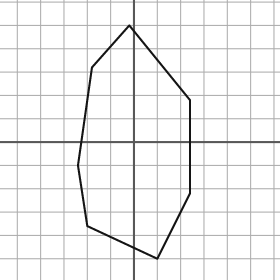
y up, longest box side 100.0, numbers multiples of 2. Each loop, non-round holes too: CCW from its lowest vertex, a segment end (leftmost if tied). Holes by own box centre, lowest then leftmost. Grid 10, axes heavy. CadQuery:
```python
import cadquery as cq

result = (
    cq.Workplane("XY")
    .moveTo(10.0, -50.0)
    .lineTo(24.0, -22.0)
    .lineTo(24.0, 18.0)
    .lineTo(-2.0, 50.0)
    .lineTo(-18.0, 32.0)
    .lineTo(-24.0, -10.0)
    .lineTo(-20.0, -36.0)
    .close()
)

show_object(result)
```